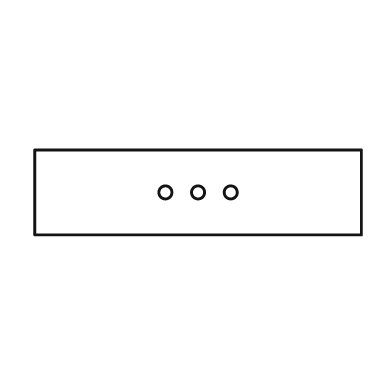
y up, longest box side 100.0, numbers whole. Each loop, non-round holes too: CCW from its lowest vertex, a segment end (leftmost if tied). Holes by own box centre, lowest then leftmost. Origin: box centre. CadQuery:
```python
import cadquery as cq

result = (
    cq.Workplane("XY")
    .moveTo(-50.0, -13.0)
    .lineTo(50.0, -13.0)
    .lineTo(50.0, 13.0)
    .lineTo(-50.0, 13.0)
    .close()
    .moveTo(-10.0, 0.0)
    .circle(2.0)
    .moveTo(0.0, 0.0)
    .circle(2.0)
    .moveTo(10.0, 0.0)
    .circle(2.0)
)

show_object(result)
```